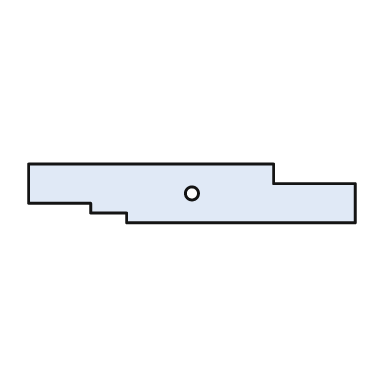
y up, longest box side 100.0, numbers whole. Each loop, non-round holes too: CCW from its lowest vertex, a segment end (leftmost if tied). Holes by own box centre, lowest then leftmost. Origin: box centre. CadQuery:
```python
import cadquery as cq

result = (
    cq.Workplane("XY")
    .moveTo(-20.0, -9.0)
    .lineTo(50.0, -9.0)
    .lineTo(50.0, 3.0)
    .lineTo(25.0, 3.0)
    .lineTo(25.0, 9.0)
    .lineTo(-50.0, 9.0)
    .lineTo(-50.0, -3.0)
    .lineTo(-31.0, -3.0)
    .lineTo(-31.0, -6.0)
    .lineTo(-20.0, -6.0)
    .close()
    .moveTo(0.0, 0.0)
    .circle(2.0)
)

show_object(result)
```